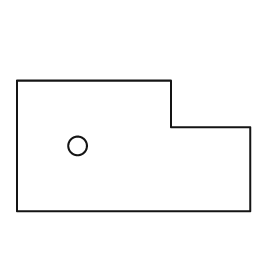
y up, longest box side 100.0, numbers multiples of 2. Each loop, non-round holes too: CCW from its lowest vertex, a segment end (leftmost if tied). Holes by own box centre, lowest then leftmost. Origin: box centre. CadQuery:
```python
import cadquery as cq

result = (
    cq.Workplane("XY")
    .moveTo(-50.0, -28.0)
    .lineTo(50.0, -28.0)
    .lineTo(50.0, 8.0)
    .lineTo(16.0, 8.0)
    .lineTo(16.0, 28.0)
    .lineTo(-50.0, 28.0)
    .close()
    .moveTo(-24.0, 0.0)
    .circle(4.0)
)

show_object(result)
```